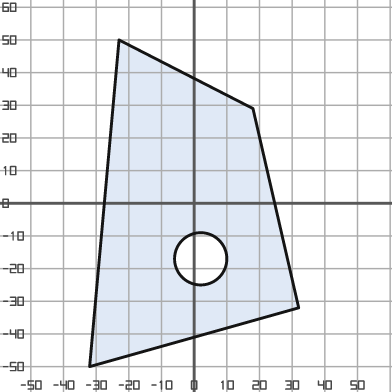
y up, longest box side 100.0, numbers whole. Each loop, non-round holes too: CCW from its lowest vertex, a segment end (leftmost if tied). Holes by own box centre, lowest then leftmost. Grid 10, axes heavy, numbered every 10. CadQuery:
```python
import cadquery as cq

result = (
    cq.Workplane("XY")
    .moveTo(-32.0, -50.0)
    .lineTo(32.0, -32.0)
    .lineTo(18.0, 29.0)
    .lineTo(-23.0, 50.0)
    .close()
    .moveTo(2.0, -17.0)
    .circle(8.0)
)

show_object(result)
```